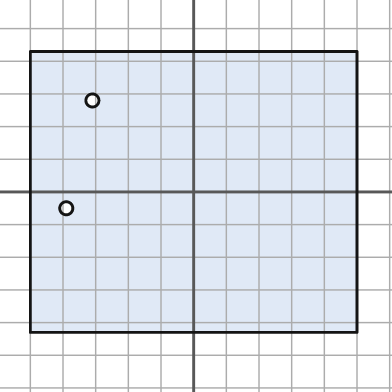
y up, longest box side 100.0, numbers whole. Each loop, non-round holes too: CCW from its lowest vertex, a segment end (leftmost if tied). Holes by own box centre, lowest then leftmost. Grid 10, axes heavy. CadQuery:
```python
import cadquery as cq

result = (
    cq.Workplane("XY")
    .moveTo(-50.0, -43.0)
    .lineTo(50.0, -43.0)
    .lineTo(50.0, 43.0)
    .lineTo(-50.0, 43.0)
    .close()
    .moveTo(-39.0, -5.0)
    .circle(2.0)
    .moveTo(-31.0, 28.0)
    .circle(2.0)
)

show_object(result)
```